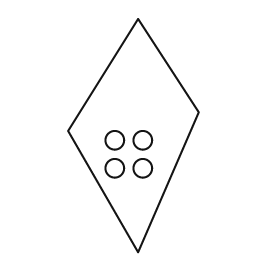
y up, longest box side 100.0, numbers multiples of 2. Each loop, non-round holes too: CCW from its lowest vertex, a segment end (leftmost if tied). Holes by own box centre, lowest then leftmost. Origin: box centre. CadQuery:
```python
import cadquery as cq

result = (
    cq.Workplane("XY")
    .moveTo(2.0, -50.0)
    .lineTo(28.0, 10.0)
    .lineTo(2.0, 50.0)
    .lineTo(-28.0, 2.0)
    .close()
    .moveTo(-8.0, -14.0)
    .circle(4.0)
    .moveTo(4.0, -14.0)
    .circle(4.0)
    .moveTo(-8.0, -2.0)
    .circle(4.0)
    .moveTo(4.0, -2.0)
    .circle(4.0)
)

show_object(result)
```